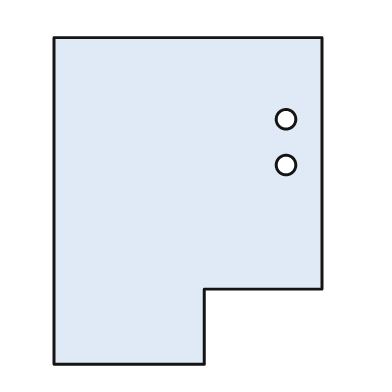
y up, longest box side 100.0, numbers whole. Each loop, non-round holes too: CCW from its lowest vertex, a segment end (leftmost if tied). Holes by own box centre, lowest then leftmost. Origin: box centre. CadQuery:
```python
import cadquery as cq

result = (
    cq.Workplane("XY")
    .moveTo(-41.0, -50.0)
    .lineTo(5.0, -50.0)
    .lineTo(5.0, -27.0)
    .lineTo(41.0, -27.0)
    .lineTo(41.0, 50.0)
    .lineTo(-41.0, 50.0)
    .close()
    .moveTo(30.0, 11.0)
    .circle(3.0)
    .moveTo(30.0, 25.0)
    .circle(3.0)
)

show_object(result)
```